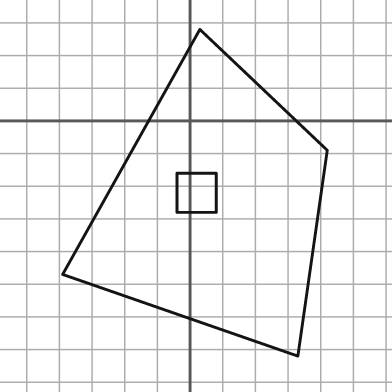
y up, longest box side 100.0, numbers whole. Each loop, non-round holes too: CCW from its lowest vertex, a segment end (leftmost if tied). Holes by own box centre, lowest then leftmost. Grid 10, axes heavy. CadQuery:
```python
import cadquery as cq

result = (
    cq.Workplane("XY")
    .moveTo(33.0, -72.0)
    .lineTo(42.0, -9.0)
    .lineTo(3.0, 28.0)
    .lineTo(-39.0, -47.0)
    .close()
    .moveTo(-4.0, -28.0)
    .lineTo(8.0, -28.0)
    .lineTo(8.0, -16.0)
    .lineTo(-4.0, -16.0)
    .close()
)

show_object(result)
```